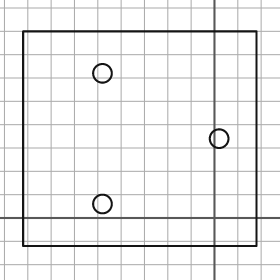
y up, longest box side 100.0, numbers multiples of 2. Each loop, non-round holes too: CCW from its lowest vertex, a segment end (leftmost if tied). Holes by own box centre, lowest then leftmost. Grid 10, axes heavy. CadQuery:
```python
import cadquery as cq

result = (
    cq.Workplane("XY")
    .moveTo(-82.0, -12.0)
    .lineTo(18.0, -12.0)
    .lineTo(18.0, 80.0)
    .lineTo(-82.0, 80.0)
    .close()
    .moveTo(-48.0, 6.0)
    .circle(4.0)
    .moveTo(2.0, 34.0)
    .circle(4.0)
    .moveTo(-48.0, 62.0)
    .circle(4.0)
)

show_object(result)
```